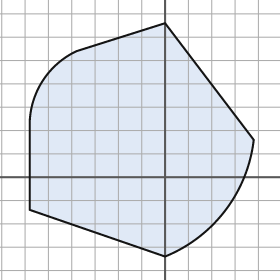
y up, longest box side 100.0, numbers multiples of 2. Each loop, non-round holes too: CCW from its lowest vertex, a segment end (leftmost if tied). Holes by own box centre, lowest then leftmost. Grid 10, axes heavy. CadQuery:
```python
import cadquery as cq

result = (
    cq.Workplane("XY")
    .moveTo(0.0, -34.0)
    .threePointArc((26.0, -14.0), (38.0, 16.0))
    .lineTo(0.0, 66.0)
    .lineTo(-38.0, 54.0)
    .threePointArc((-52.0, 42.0), (-58.0, 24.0))
    .lineTo(-58.0, -14.0)
    .close()
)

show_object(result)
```